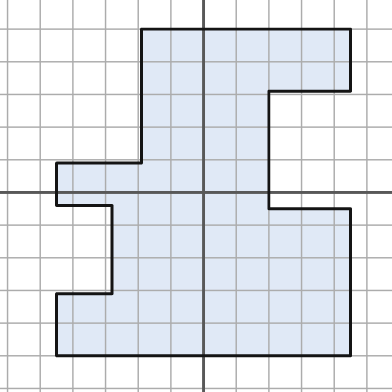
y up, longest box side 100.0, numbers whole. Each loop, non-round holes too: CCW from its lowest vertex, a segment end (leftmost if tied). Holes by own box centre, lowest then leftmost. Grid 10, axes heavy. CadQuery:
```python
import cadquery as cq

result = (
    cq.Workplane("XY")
    .moveTo(-45.0, -50.0)
    .lineTo(45.0, -50.0)
    .lineTo(45.0, -5.0)
    .lineTo(20.0, -5.0)
    .lineTo(20.0, 31.0)
    .lineTo(45.0, 31.0)
    .lineTo(45.0, 50.0)
    .lineTo(-19.0, 50.0)
    .lineTo(-19.0, 9.0)
    .lineTo(-45.0, 9.0)
    .lineTo(-45.0, -4.0)
    .lineTo(-28.0, -4.0)
    .lineTo(-28.0, -31.0)
    .lineTo(-45.0, -31.0)
    .close()
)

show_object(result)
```